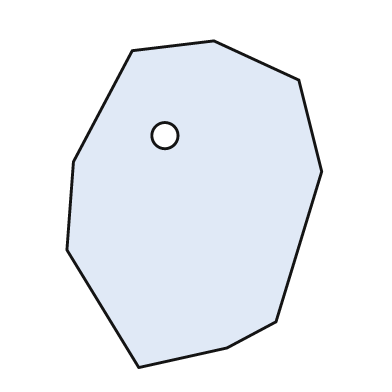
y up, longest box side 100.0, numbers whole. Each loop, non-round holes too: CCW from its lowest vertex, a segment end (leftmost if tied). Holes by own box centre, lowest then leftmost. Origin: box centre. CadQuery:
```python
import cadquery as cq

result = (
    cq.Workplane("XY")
    .moveTo(-17.0, -50.0)
    .lineTo(10.0, -44.0)
    .lineTo(25.0, -36.0)
    .lineTo(39.0, 10.0)
    .lineTo(32.0, 38.0)
    .lineTo(6.0, 50.0)
    .lineTo(-19.0, 47.0)
    .lineTo(-37.0, 13.0)
    .lineTo(-39.0, -14.0)
    .close()
    .moveTo(-9.0, 21.0)
    .circle(4.0)
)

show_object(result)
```